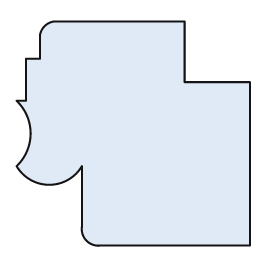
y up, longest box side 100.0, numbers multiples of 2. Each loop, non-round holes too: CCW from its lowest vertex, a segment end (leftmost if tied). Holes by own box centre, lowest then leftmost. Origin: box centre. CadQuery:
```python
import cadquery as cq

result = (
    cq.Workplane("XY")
    .moveTo(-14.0, -48.0)
    .lineTo(50.0, -48.0)
    .lineTo(50.0, 22.0)
    .lineTo(22.0, 22.0)
    .lineTo(22.0, 48.0)
    .lineTo(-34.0, 48.0)
    .threePointArc((-38.0, 46.0), (-40.0, 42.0))
    .lineTo(-40.0, 32.0)
    .lineTo(-46.0, 32.0)
    .lineTo(-46.0, 14.0)
    .lineTo(-50.0, 14.0)
    .threePointArc((-44.0, 0.0), (-50.0, -14.0))
    .threePointArc((-36.0, -22.0), (-22.0, -14.0))
    .lineTo(-22.0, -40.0)
    .threePointArc((-20.0, -46.0), (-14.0, -48.0))
    .close()
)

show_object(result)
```